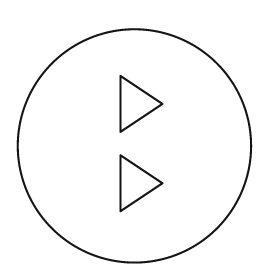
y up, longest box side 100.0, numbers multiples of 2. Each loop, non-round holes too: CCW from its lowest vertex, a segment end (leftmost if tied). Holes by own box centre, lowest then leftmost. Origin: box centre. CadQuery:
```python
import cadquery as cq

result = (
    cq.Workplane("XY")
    .moveTo(0.0, 0.0)
    .circle(50.0)
    .moveTo(-6.0, -28.0)
    .lineTo(12.0, -16.0)
    .lineTo(-6.0, -4.0)
    .close()
    .moveTo(-6.0, 6.0)
    .lineTo(12.0, 18.0)
    .lineTo(-6.0, 30.0)
    .close()
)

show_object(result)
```